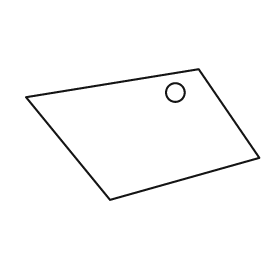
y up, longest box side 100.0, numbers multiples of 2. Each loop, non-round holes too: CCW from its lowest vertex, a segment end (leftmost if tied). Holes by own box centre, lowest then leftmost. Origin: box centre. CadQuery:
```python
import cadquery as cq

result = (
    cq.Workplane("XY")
    .moveTo(-14.0, -28.0)
    .lineTo(50.0, -10.0)
    .lineTo(24.0, 28.0)
    .lineTo(-50.0, 16.0)
    .close()
    .moveTo(14.0, 18.0)
    .circle(4.0)
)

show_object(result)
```